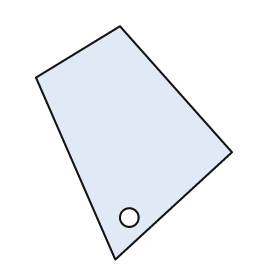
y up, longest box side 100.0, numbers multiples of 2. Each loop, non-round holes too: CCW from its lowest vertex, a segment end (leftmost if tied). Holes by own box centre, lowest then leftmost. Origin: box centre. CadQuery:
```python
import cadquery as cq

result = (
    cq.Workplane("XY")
    .moveTo(-8.0, -50.0)
    .lineTo(42.0, -4.0)
    .lineTo(-6.0, 50.0)
    .lineTo(-42.0, 28.0)
    .close()
    .moveTo(-2.0, -32.0)
    .circle(4.0)
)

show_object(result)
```